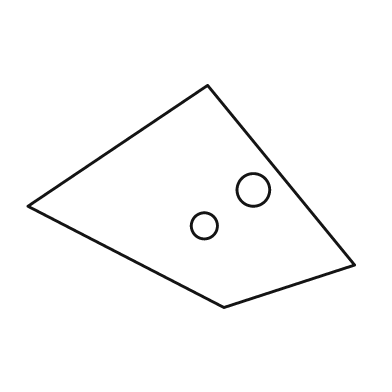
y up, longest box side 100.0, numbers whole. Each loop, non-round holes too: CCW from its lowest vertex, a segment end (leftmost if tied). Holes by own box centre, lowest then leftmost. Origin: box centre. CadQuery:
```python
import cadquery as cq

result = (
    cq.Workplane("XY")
    .moveTo(10.0, -34.0)
    .lineTo(50.0, -21.0)
    .lineTo(5.0, 34.0)
    .lineTo(-50.0, -3.0)
    .close()
    .moveTo(4.0, -9.0)
    .circle(4.0)
    .moveTo(19.0, 2.0)
    .circle(5.0)
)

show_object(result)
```